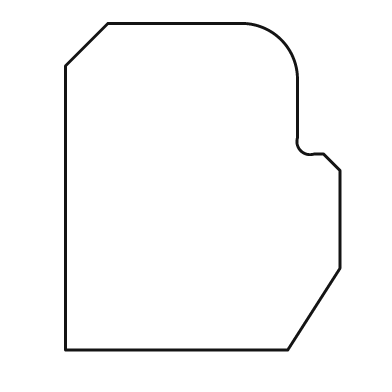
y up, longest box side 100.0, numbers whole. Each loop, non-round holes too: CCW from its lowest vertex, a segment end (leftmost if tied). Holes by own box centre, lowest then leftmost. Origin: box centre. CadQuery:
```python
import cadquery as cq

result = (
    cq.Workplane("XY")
    .moveTo(-42.0, -50.0)
    .lineTo(26.0, -50.0)
    .lineTo(42.0, -25.0)
    .lineTo(42.0, 5.0)
    .lineTo(37.0, 10.0)
    .lineTo(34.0, 10.0)
    .threePointArc((30.0, 11.0), (29.0, 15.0))
    .lineTo(29.0, 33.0)
    .threePointArc((24.0, 45.0), (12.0, 50.0))
    .lineTo(-29.0, 50.0)
    .lineTo(-42.0, 37.0)
    .close()
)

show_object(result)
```